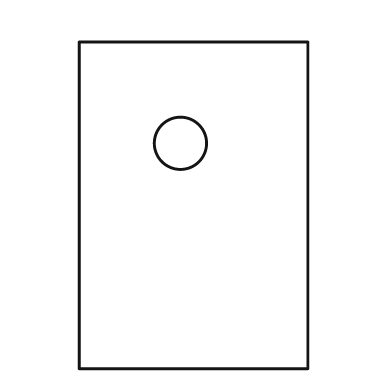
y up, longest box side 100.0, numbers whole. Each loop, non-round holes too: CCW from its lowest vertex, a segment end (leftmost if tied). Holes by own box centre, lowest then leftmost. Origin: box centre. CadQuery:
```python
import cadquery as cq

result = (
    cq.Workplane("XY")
    .moveTo(-35.0, -50.0)
    .lineTo(35.0, -50.0)
    .lineTo(35.0, 50.0)
    .lineTo(-35.0, 50.0)
    .close()
    .moveTo(-4.0, 19.0)
    .circle(8.0)
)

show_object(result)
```